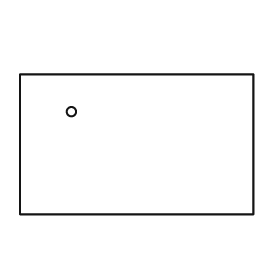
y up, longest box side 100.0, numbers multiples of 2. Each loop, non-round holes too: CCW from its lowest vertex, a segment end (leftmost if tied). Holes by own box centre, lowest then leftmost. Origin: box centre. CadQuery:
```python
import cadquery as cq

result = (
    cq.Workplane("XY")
    .moveTo(-50.0, -30.0)
    .lineTo(50.0, -30.0)
    .lineTo(50.0, 30.0)
    .lineTo(-50.0, 30.0)
    .close()
    .moveTo(-28.0, 14.0)
    .circle(2.0)
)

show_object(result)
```